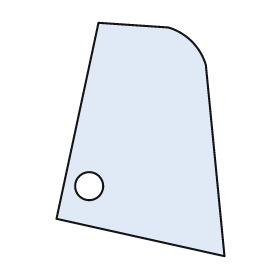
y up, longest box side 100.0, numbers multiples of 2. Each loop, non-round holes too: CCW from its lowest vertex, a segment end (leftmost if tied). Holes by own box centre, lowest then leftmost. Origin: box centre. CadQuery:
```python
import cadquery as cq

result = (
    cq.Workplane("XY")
    .moveTo(36.0, -50.0)
    .lineTo(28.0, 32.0)
    .threePointArc((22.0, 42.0), (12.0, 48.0))
    .lineTo(-18.0, 50.0)
    .lineTo(-36.0, -34.0)
    .close()
    .moveTo(-22.0, -20.0)
    .circle(6.0)
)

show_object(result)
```